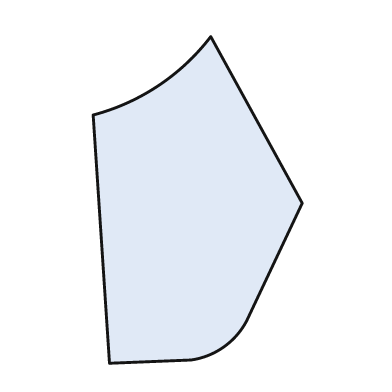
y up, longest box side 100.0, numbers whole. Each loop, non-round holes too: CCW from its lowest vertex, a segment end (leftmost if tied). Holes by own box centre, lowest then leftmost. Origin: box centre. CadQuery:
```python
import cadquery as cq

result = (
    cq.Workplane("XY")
    .moveTo(-27.0, -50.0)
    .lineTo(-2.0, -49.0)
    .threePointArc((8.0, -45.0), (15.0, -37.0))
    .lineTo(32.0, -1.0)
    .lineTo(4.0, 50.0)
    .threePointArc((-12.0, 35.0), (-32.0, 26.0))
    .close()
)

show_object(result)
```